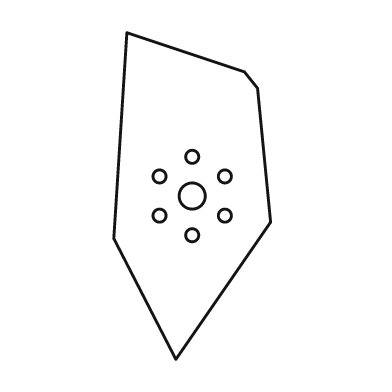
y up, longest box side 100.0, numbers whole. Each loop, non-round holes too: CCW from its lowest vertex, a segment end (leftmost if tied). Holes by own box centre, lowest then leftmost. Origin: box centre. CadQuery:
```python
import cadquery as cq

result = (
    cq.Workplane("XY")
    .moveTo(-5.0, -50.0)
    .lineTo(24.0, -8.0)
    .lineTo(20.0, 33.0)
    .lineTo(16.0, 38.0)
    .lineTo(-20.0, 50.0)
    .lineTo(-24.0, -13.0)
    .close()
    .moveTo(0.0, -12.0)
    .circle(2.0)
    .moveTo(-10.0, -6.0)
    .circle(2.0)
    .moveTo(10.0, -6.0)
    .circle(2.0)
    .moveTo(0.0, 0.0)
    .circle(4.0)
    .moveTo(-10.0, 6.0)
    .circle(2.0)
    .moveTo(10.0, 6.0)
    .circle(2.0)
    .moveTo(0.0, 12.0)
    .circle(2.0)
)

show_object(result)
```